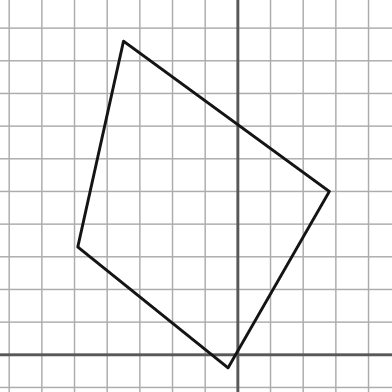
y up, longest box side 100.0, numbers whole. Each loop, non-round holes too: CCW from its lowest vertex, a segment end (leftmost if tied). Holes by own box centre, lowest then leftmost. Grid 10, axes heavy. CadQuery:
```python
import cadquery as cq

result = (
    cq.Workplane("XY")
    .moveTo(-3.0, -4.0)
    .lineTo(28.0, 50.0)
    .lineTo(-35.0, 96.0)
    .lineTo(-49.0, 33.0)
    .close()
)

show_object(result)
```